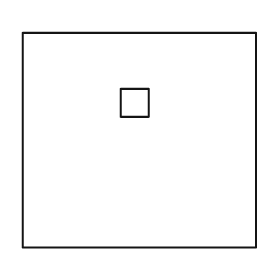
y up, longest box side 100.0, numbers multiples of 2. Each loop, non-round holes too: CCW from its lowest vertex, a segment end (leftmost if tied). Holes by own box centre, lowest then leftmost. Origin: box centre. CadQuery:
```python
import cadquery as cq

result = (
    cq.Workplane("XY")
    .moveTo(-50.0, -46.0)
    .lineTo(50.0, -46.0)
    .lineTo(50.0, 46.0)
    .lineTo(-50.0, 46.0)
    .close()
    .moveTo(-8.0, 10.0)
    .lineTo(4.0, 10.0)
    .lineTo(4.0, 22.0)
    .lineTo(-8.0, 22.0)
    .close()
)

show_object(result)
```